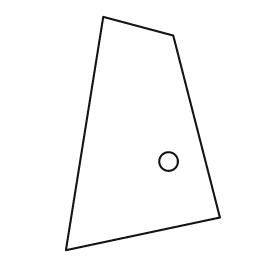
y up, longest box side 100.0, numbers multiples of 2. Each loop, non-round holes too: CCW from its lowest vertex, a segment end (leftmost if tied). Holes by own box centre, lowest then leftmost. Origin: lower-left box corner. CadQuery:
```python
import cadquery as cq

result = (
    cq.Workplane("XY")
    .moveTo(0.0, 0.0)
    .lineTo(66.0, 14.0)
    .lineTo(46.0, 92.0)
    .lineTo(16.0, 100.0)
    .close()
    .moveTo(44.0, 38.0)
    .circle(4.0)
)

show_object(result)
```